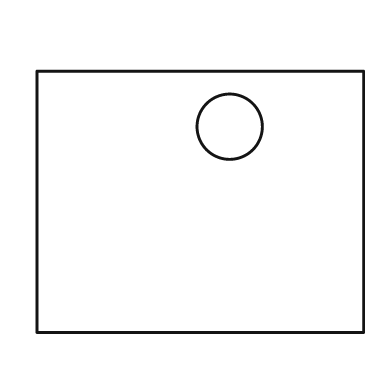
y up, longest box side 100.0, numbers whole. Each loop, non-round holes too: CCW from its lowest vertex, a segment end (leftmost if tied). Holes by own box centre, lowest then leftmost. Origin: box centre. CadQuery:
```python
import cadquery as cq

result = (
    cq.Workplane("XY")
    .moveTo(-50.0, -40.0)
    .lineTo(50.0, -40.0)
    .lineTo(50.0, 40.0)
    .lineTo(-50.0, 40.0)
    .close()
    .moveTo(9.0, 23.0)
    .circle(10.0)
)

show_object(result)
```